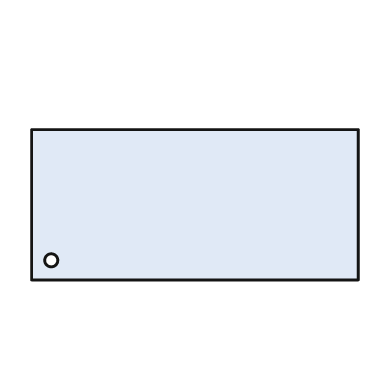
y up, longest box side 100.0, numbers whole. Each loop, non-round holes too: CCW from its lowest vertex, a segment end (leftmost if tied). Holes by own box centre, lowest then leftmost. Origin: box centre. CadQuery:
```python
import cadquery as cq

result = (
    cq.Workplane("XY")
    .moveTo(-50.0, -23.0)
    .lineTo(50.0, -23.0)
    .lineTo(50.0, 23.0)
    .lineTo(-50.0, 23.0)
    .close()
    .moveTo(-44.0, -17.0)
    .circle(2.0)
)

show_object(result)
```